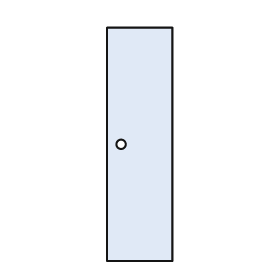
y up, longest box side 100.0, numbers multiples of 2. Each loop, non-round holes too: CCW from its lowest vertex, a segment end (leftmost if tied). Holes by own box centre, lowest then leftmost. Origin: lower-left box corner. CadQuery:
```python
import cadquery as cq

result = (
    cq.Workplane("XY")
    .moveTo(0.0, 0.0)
    .lineTo(28.0, 0.0)
    .lineTo(28.0, 100.0)
    .lineTo(0.0, 100.0)
    .close()
    .moveTo(6.0, 50.0)
    .circle(2.0)
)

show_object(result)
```